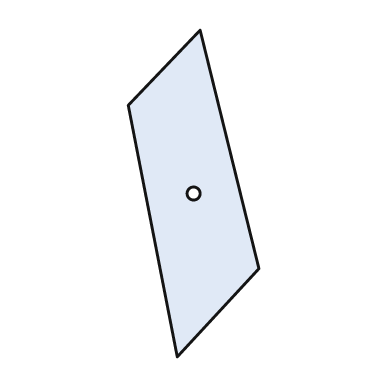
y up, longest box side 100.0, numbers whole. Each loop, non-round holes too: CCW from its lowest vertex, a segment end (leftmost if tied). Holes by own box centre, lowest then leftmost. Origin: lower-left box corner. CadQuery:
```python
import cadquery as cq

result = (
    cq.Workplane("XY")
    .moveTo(15.0, 0.0)
    .lineTo(40.0, 27.0)
    .lineTo(22.0, 100.0)
    .lineTo(0.0, 77.0)
    .close()
    .moveTo(20.0, 50.0)
    .circle(2.0)
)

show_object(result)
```